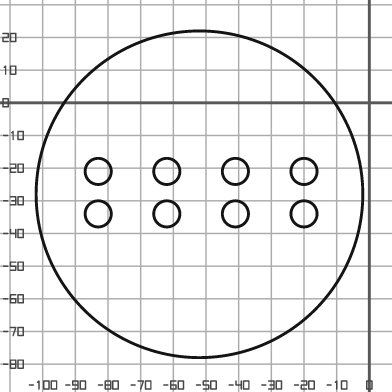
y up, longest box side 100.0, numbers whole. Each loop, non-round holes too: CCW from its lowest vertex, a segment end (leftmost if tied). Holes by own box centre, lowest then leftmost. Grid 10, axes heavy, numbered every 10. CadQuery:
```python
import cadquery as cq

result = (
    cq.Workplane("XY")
    .moveTo(-52.0, -28.0)
    .circle(50.0)
    .moveTo(-83.0, -34.0)
    .circle(4.0)
    .moveTo(-62.0, -34.0)
    .circle(4.0)
    .moveTo(-41.0, -34.0)
    .circle(4.0)
    .moveTo(-20.0, -34.0)
    .circle(4.0)
    .moveTo(-83.0, -21.0)
    .circle(4.0)
    .moveTo(-62.0, -21.0)
    .circle(4.0)
    .moveTo(-41.0, -21.0)
    .circle(4.0)
    .moveTo(-20.0, -21.0)
    .circle(4.0)
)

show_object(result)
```